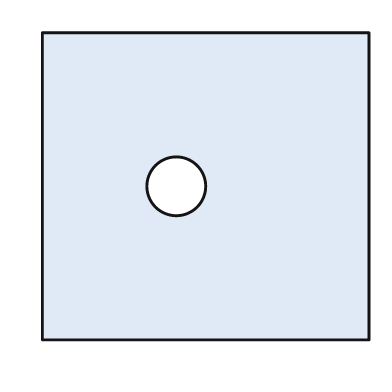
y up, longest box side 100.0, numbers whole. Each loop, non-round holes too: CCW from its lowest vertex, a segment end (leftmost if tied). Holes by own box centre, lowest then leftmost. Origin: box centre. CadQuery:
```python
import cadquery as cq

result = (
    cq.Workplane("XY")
    .moveTo(-50.0, -47.0)
    .lineTo(50.0, -47.0)
    .lineTo(50.0, 47.0)
    .lineTo(-50.0, 47.0)
    .close()
    .moveTo(-9.0, 0.0)
    .circle(9.0)
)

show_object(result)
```